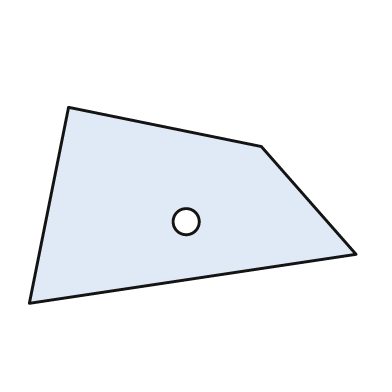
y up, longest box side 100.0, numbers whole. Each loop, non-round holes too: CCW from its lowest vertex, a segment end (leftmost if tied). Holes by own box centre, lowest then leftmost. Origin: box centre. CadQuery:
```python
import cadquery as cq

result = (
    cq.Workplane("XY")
    .moveTo(-50.0, -30.0)
    .lineTo(50.0, -15.0)
    .lineTo(21.0, 18.0)
    .lineTo(-38.0, 30.0)
    .close()
    .moveTo(-2.0, -5.0)
    .circle(4.0)
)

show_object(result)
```